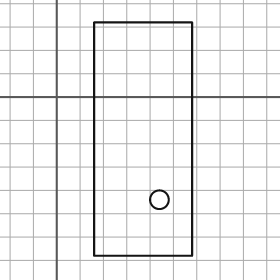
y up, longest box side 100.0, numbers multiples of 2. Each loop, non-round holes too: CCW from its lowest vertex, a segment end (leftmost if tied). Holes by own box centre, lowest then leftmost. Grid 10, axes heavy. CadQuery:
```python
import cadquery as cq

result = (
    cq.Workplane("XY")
    .moveTo(16.0, -68.0)
    .lineTo(58.0, -68.0)
    .lineTo(58.0, 32.0)
    .lineTo(16.0, 32.0)
    .close()
    .moveTo(44.0, -44.0)
    .circle(4.0)
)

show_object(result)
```